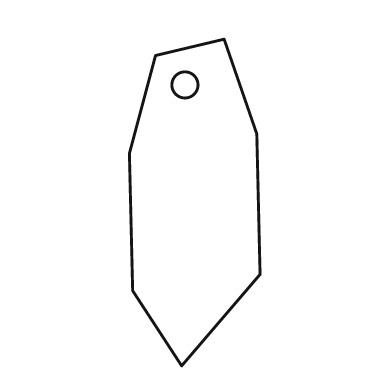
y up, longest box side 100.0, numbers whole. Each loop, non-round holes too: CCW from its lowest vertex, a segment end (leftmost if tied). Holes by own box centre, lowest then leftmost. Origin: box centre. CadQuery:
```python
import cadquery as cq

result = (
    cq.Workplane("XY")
    .moveTo(-4.0, -50.0)
    .lineTo(20.0, -22.0)
    .lineTo(19.0, 21.0)
    .lineTo(9.0, 50.0)
    .lineTo(-12.0, 45.0)
    .lineTo(-20.0, 15.0)
    .lineTo(-19.0, -27.0)
    .close()
    .moveTo(-3.0, 36.0)
    .circle(4.0)
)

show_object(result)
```